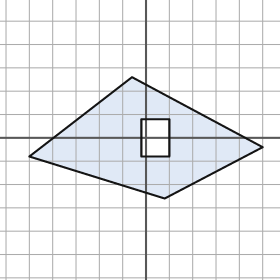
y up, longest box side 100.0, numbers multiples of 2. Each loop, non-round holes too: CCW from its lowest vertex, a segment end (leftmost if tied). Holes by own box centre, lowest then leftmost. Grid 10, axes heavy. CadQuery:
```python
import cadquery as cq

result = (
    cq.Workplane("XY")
    .moveTo(8.0, -26.0)
    .lineTo(50.0, -4.0)
    .lineTo(-6.0, 26.0)
    .lineTo(-50.0, -8.0)
    .close()
    .moveTo(-2.0, -8.0)
    .lineTo(10.0, -8.0)
    .lineTo(10.0, 8.0)
    .lineTo(-2.0, 8.0)
    .close()
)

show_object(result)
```